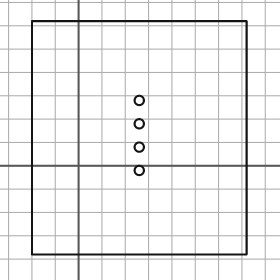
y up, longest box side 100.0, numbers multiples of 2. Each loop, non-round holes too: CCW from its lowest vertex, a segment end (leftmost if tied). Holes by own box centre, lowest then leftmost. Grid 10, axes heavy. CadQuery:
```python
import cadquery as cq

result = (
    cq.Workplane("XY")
    .moveTo(-20.0, -38.0)
    .lineTo(72.0, -38.0)
    .lineTo(72.0, 62.0)
    .lineTo(-20.0, 62.0)
    .close()
    .moveTo(26.0, -2.0)
    .circle(2.0)
    .moveTo(26.0, 8.0)
    .circle(2.0)
    .moveTo(26.0, 18.0)
    .circle(2.0)
    .moveTo(26.0, 28.0)
    .circle(2.0)
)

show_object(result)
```